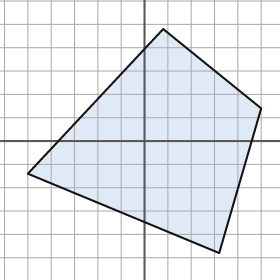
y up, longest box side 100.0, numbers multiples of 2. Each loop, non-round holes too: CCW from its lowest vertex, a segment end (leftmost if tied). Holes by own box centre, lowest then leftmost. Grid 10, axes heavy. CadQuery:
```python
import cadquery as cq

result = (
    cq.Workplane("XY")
    .moveTo(32.0, -48.0)
    .lineTo(50.0, 14.0)
    .lineTo(8.0, 48.0)
    .lineTo(-50.0, -14.0)
    .close()
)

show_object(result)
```